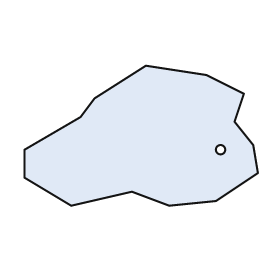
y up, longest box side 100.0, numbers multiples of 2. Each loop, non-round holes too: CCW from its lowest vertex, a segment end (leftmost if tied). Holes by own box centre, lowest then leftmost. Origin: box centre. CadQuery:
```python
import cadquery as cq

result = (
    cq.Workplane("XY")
    .moveTo(-30.0, -30.0)
    .lineTo(-4.0, -24.0)
    .lineTo(12.0, -30.0)
    .lineTo(32.0, -28.0)
    .lineTo(50.0, -16.0)
    .lineTo(48.0, -4.0)
    .lineTo(40.0, 6.0)
    .lineTo(44.0, 18.0)
    .lineTo(28.0, 26.0)
    .lineTo(2.0, 30.0)
    .lineTo(-20.0, 16.0)
    .lineTo(-26.0, 8.0)
    .lineTo(-50.0, -6.0)
    .lineTo(-50.0, -18.0)
    .close()
    .moveTo(34.0, -6.0)
    .circle(2.0)
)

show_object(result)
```